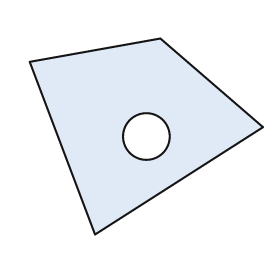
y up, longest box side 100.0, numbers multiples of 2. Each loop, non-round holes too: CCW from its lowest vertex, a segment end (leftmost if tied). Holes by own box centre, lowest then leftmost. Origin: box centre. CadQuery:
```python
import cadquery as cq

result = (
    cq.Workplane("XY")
    .moveTo(-22.0, -42.0)
    .lineTo(50.0, 4.0)
    .lineTo(6.0, 42.0)
    .lineTo(-50.0, 32.0)
    .close()
    .moveTo(0.0, 0.0)
    .circle(10.0)
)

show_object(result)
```